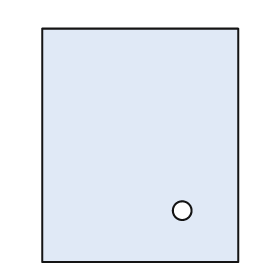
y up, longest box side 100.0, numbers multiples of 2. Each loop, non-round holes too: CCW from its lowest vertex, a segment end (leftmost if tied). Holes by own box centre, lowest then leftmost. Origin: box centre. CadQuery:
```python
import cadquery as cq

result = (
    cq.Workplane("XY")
    .moveTo(-42.0, -50.0)
    .lineTo(42.0, -50.0)
    .lineTo(42.0, 50.0)
    .lineTo(-42.0, 50.0)
    .close()
    .moveTo(18.0, -28.0)
    .circle(4.0)
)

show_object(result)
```